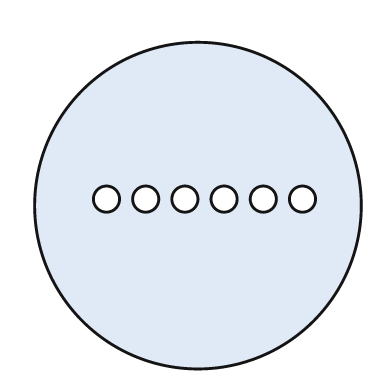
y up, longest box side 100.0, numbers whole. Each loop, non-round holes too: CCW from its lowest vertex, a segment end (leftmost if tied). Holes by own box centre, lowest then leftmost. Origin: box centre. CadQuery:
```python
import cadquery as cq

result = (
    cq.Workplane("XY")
    .moveTo(0.0, 0.0)
    .circle(50.0)
    .moveTo(-28.0, 2.0)
    .circle(4.0)
    .moveTo(-16.0, 2.0)
    .circle(4.0)
    .moveTo(-4.0, 2.0)
    .circle(4.0)
    .moveTo(8.0, 2.0)
    .circle(4.0)
    .moveTo(20.0, 2.0)
    .circle(4.0)
    .moveTo(32.0, 2.0)
    .circle(4.0)
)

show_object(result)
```